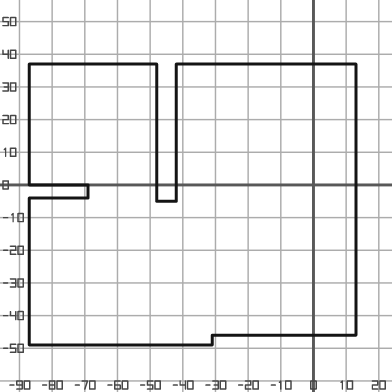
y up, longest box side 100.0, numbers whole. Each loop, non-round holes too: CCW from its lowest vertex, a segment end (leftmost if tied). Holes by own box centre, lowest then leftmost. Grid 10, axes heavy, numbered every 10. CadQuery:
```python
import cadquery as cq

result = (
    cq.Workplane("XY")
    .moveTo(-87.0, -49.0)
    .lineTo(-31.0, -49.0)
    .lineTo(-31.0, -46.0)
    .lineTo(13.0, -46.0)
    .lineTo(13.0, 37.0)
    .lineTo(-42.0, 37.0)
    .lineTo(-42.0, -5.0)
    .lineTo(-48.0, -5.0)
    .lineTo(-48.0, 37.0)
    .lineTo(-87.0, 37.0)
    .lineTo(-87.0, 0.0)
    .lineTo(-69.0, 0.0)
    .lineTo(-69.0, -4.0)
    .lineTo(-87.0, -4.0)
    .close()
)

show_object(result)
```